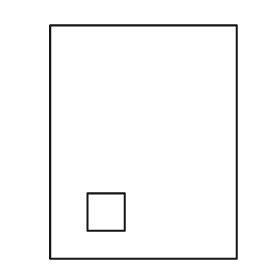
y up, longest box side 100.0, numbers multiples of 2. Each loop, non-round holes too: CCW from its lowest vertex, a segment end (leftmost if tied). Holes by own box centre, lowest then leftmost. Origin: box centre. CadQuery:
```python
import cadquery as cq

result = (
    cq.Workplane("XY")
    .moveTo(-40.0, -50.0)
    .lineTo(40.0, -50.0)
    .lineTo(40.0, 50.0)
    .lineTo(-40.0, 50.0)
    .close()
    .moveTo(-24.0, -38.0)
    .lineTo(-8.0, -38.0)
    .lineTo(-8.0, -22.0)
    .lineTo(-24.0, -22.0)
    .close()
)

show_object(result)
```